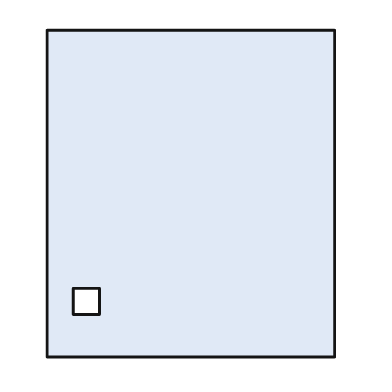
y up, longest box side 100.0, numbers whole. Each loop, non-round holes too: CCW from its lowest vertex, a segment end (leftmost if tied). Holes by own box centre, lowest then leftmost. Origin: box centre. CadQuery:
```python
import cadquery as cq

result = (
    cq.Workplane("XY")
    .moveTo(-44.0, -50.0)
    .lineTo(44.0, -50.0)
    .lineTo(44.0, 50.0)
    .lineTo(-44.0, 50.0)
    .close()
    .moveTo(-36.0, -37.0)
    .lineTo(-28.0, -37.0)
    .lineTo(-28.0, -29.0)
    .lineTo(-36.0, -29.0)
    .close()
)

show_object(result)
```